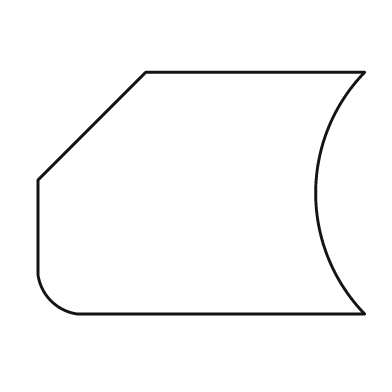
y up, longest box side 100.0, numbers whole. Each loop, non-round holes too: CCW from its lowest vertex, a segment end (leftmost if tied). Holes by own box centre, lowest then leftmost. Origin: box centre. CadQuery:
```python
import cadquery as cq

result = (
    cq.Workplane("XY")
    .moveTo(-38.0, -37.0)
    .lineTo(50.0, -37.0)
    .threePointArc((35.0, 0.0), (50.0, 37.0))
    .lineTo(-17.0, 37.0)
    .lineTo(-50.0, 4.0)
    .lineTo(-50.0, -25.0)
    .threePointArc((-46.0, -33.0), (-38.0, -37.0))
    .close()
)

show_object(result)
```